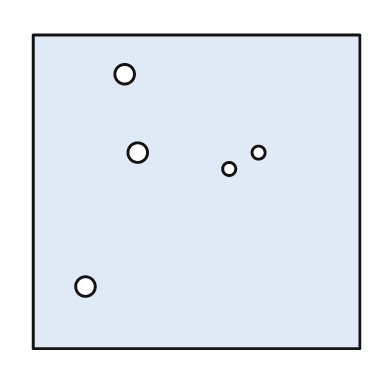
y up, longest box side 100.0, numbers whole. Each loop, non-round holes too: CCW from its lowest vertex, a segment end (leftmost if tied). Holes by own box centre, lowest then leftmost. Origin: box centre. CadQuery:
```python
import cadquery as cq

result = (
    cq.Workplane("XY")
    .moveTo(-50.0, -48.0)
    .lineTo(50.0, -48.0)
    .lineTo(50.0, 48.0)
    .lineTo(-50.0, 48.0)
    .close()
    .moveTo(-34.0, -29.0)
    .circle(3.0)
    .moveTo(10.0, 7.0)
    .circle(2.0)
    .moveTo(-18.0, 12.0)
    .circle(3.0)
    .moveTo(19.0, 12.0)
    .circle(2.0)
    .moveTo(-22.0, 36.0)
    .circle(3.0)
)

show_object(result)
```